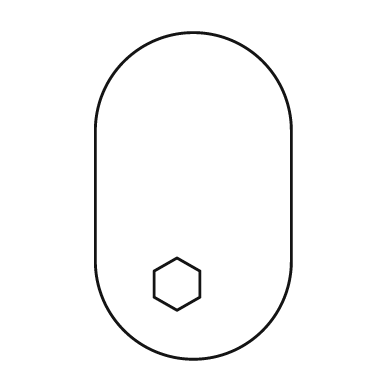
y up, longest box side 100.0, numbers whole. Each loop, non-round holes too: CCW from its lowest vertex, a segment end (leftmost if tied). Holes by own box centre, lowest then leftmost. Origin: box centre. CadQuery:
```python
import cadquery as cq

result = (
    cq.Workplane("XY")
    .moveTo(-30.0, -20.0)
    .threePointArc((0.0, -50.0), (30.0, -20.0))
    .lineTo(30.0, 20.0)
    .threePointArc((0.0, 50.0), (-30.0, 20.0))
    .close()
    .moveTo(-5.0, -35.0)
    .lineTo(2.0, -31.0)
    .lineTo(2.0, -23.0)
    .lineTo(-5.0, -19.0)
    .lineTo(-12.0, -23.0)
    .lineTo(-12.0, -31.0)
    .close()
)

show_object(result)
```